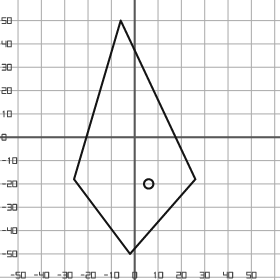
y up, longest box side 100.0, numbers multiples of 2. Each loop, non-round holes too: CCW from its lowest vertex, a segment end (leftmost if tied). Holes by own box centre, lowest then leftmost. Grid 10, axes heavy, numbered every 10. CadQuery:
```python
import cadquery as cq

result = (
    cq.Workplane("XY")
    .moveTo(-2.0, -50.0)
    .lineTo(26.0, -18.0)
    .lineTo(-6.0, 50.0)
    .lineTo(-26.0, -18.0)
    .close()
    .moveTo(6.0, -20.0)
    .circle(2.0)
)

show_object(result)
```